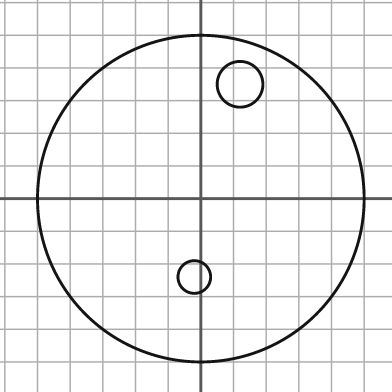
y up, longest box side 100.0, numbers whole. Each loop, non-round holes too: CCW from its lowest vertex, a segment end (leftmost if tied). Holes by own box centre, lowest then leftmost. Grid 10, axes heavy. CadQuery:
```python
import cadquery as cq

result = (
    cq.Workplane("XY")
    .moveTo(0.0, 0.0)
    .circle(50.0)
    .moveTo(-2.0, -24.0)
    .circle(5.0)
    .moveTo(12.0, 35.0)
    .circle(7.0)
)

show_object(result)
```